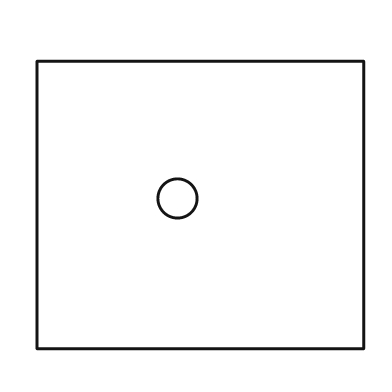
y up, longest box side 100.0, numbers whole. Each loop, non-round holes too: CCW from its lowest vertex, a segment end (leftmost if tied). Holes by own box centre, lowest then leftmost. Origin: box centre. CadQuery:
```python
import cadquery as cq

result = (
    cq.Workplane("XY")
    .moveTo(-50.0, -44.0)
    .lineTo(50.0, -44.0)
    .lineTo(50.0, 44.0)
    .lineTo(-50.0, 44.0)
    .close()
    .moveTo(-7.0, 2.0)
    .circle(6.0)
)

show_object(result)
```